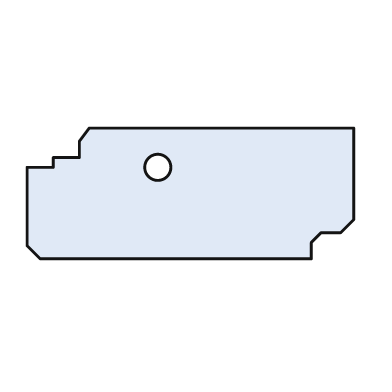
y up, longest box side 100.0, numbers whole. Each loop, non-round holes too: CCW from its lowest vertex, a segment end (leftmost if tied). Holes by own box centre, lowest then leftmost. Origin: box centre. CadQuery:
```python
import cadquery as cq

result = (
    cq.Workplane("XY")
    .moveTo(-46.0, -20.0)
    .lineTo(37.0, -20.0)
    .lineTo(37.0, -15.0)
    .lineTo(40.0, -12.0)
    .lineTo(46.0, -12.0)
    .lineTo(50.0, -8.0)
    .lineTo(50.0, 20.0)
    .lineTo(-31.0, 20.0)
    .lineTo(-34.0, 16.0)
    .lineTo(-34.0, 11.0)
    .lineTo(-42.0, 11.0)
    .lineTo(-42.0, 8.0)
    .lineTo(-50.0, 8.0)
    .lineTo(-50.0, -16.0)
    .close()
    .moveTo(-10.0, 8.0)
    .circle(4.0)
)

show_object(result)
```